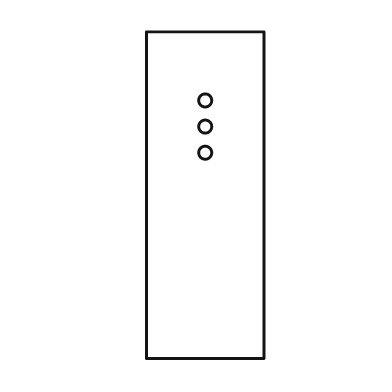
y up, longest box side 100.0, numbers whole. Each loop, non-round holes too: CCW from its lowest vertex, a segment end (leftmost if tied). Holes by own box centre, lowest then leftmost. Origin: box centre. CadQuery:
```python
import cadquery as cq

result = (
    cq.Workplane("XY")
    .moveTo(-18.0, -50.0)
    .lineTo(18.0, -50.0)
    .lineTo(18.0, 50.0)
    .lineTo(-18.0, 50.0)
    .close()
    .moveTo(0.0, 13.0)
    .circle(2.0)
    .moveTo(0.0, 21.0)
    .circle(2.0)
    .moveTo(0.0, 29.0)
    .circle(2.0)
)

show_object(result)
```